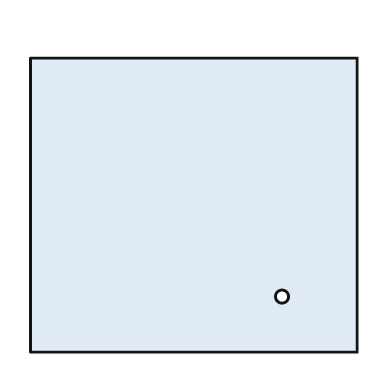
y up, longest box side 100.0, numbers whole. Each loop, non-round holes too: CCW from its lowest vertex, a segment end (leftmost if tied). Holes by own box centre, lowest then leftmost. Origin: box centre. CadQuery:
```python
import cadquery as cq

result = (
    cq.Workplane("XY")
    .moveTo(-50.0, -45.0)
    .lineTo(50.0, -45.0)
    .lineTo(50.0, 45.0)
    .lineTo(-50.0, 45.0)
    .close()
    .moveTo(27.0, -28.0)
    .circle(2.0)
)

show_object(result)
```